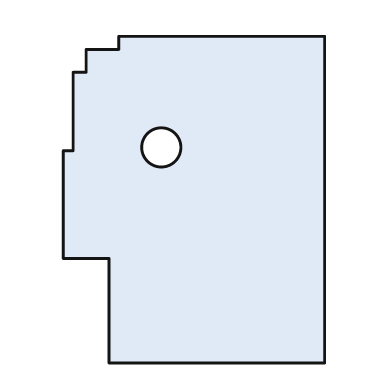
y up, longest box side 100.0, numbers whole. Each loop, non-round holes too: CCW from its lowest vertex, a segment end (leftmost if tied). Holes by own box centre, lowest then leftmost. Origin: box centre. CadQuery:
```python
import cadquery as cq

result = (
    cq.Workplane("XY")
    .moveTo(-26.0, -50.0)
    .lineTo(40.0, -50.0)
    .lineTo(40.0, 50.0)
    .lineTo(-23.0, 50.0)
    .lineTo(-23.0, 46.0)
    .lineTo(-33.0, 46.0)
    .lineTo(-33.0, 39.0)
    .lineTo(-37.0, 39.0)
    .lineTo(-37.0, 15.0)
    .lineTo(-40.0, 15.0)
    .lineTo(-40.0, -18.0)
    .lineTo(-26.0, -18.0)
    .close()
    .moveTo(-10.0, 16.0)
    .circle(6.0)
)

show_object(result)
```